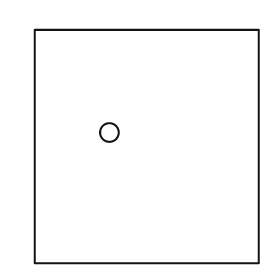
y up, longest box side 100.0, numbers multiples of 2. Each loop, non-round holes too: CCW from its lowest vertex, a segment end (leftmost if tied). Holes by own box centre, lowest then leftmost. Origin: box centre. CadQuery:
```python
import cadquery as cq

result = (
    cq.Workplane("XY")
    .moveTo(-48.0, -50.0)
    .lineTo(48.0, -50.0)
    .lineTo(48.0, 50.0)
    .lineTo(-48.0, 50.0)
    .close()
    .moveTo(-16.0, 6.0)
    .circle(4.0)
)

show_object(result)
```